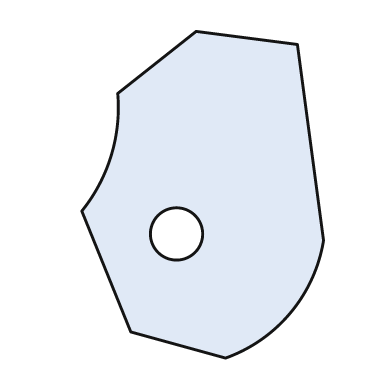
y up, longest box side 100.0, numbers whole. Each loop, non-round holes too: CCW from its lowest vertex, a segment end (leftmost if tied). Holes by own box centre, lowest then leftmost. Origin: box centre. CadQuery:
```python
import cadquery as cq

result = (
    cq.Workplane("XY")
    .moveTo(7.0, -50.0)
    .threePointArc((27.0, -36.0), (37.0, -14.0))
    .lineTo(29.0, 46.0)
    .lineTo(-2.0, 50.0)
    .lineTo(-26.0, 31.0)
    .threePointArc((-28.0, 12.0), (-37.0, -5.0))
    .lineTo(-22.0, -42.0)
    .close()
    .moveTo(-8.0, -12.0)
    .circle(8.0)
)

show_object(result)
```